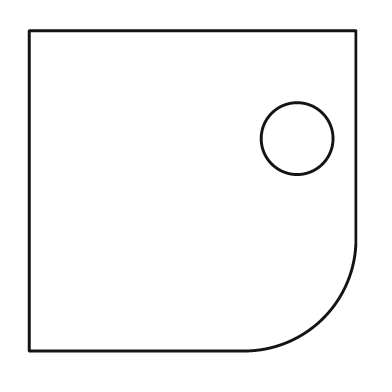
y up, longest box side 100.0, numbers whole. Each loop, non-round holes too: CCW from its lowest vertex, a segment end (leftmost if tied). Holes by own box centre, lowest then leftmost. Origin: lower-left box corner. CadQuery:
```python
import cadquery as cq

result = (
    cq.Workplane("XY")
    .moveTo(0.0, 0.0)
    .lineTo(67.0, 0.0)
    .threePointArc((90.0, 10.0), (100.0, 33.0))
    .lineTo(100.0, 98.0)
    .lineTo(0.0, 98.0)
    .close()
    .moveTo(82.0, 65.0)
    .circle(11.0)
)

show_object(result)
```